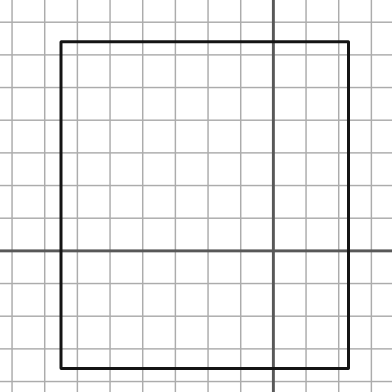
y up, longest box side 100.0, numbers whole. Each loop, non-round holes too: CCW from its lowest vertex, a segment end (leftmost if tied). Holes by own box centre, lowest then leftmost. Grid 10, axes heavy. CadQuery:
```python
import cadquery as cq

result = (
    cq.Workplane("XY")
    .moveTo(-65.0, -36.0)
    .lineTo(23.0, -36.0)
    .lineTo(23.0, 64.0)
    .lineTo(-65.0, 64.0)
    .close()
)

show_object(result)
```